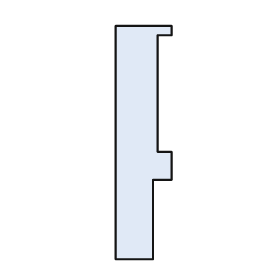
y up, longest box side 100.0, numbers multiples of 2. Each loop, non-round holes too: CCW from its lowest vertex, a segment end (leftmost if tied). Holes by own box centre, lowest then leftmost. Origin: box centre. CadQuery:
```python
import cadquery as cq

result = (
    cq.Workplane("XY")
    .moveTo(-12.0, -50.0)
    .lineTo(4.0, -50.0)
    .lineTo(4.0, -16.0)
    .lineTo(12.0, -16.0)
    .lineTo(12.0, -4.0)
    .lineTo(6.0, -4.0)
    .lineTo(6.0, 46.0)
    .lineTo(12.0, 46.0)
    .lineTo(12.0, 50.0)
    .lineTo(-12.0, 50.0)
    .close()
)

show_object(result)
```